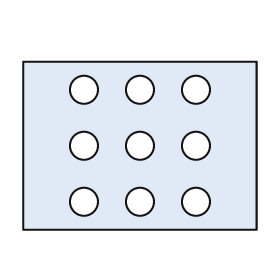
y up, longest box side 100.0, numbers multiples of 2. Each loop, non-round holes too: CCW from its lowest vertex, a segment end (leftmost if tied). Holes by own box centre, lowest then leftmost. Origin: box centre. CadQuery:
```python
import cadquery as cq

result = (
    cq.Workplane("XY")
    .moveTo(-50.0, -36.0)
    .lineTo(50.0, -36.0)
    .lineTo(50.0, 36.0)
    .lineTo(-50.0, 36.0)
    .close()
    .moveTo(-24.0, -24.0)
    .circle(6.0)
    .moveTo(0.0, -24.0)
    .circle(6.0)
    .moveTo(24.0, -24.0)
    .circle(6.0)
    .moveTo(-24.0, 0.0)
    .circle(6.0)
    .moveTo(0.0, 0.0)
    .circle(6.0)
    .moveTo(24.0, 0.0)
    .circle(6.0)
    .moveTo(-24.0, 24.0)
    .circle(6.0)
    .moveTo(0.0, 24.0)
    .circle(6.0)
    .moveTo(24.0, 24.0)
    .circle(6.0)
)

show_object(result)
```